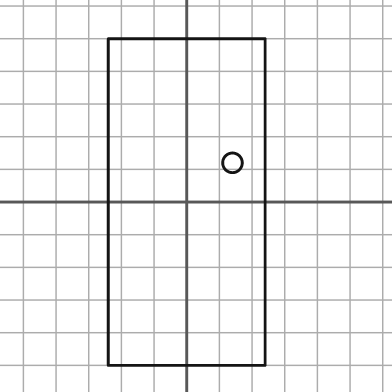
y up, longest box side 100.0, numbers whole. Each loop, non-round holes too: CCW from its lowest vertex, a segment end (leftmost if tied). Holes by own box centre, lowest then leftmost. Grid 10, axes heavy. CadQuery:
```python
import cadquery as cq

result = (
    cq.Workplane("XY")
    .moveTo(-24.0, -50.0)
    .lineTo(24.0, -50.0)
    .lineTo(24.0, 50.0)
    .lineTo(-24.0, 50.0)
    .close()
    .moveTo(14.0, 12.0)
    .circle(3.0)
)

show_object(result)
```